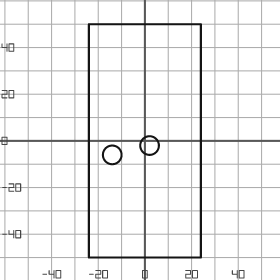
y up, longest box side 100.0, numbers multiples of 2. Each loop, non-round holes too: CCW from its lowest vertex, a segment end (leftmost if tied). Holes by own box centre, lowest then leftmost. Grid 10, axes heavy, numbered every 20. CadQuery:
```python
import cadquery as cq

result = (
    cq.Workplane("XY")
    .moveTo(-24.0, -50.0)
    .lineTo(24.0, -50.0)
    .lineTo(24.0, 50.0)
    .lineTo(-24.0, 50.0)
    .close()
    .moveTo(-14.0, -6.0)
    .circle(4.0)
    .moveTo(2.0, -2.0)
    .circle(4.0)
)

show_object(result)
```